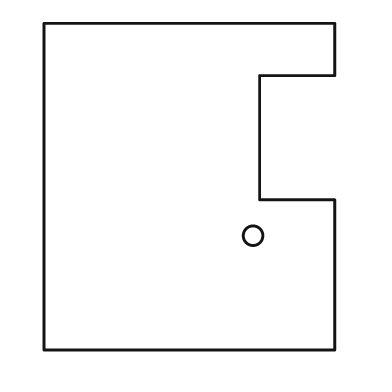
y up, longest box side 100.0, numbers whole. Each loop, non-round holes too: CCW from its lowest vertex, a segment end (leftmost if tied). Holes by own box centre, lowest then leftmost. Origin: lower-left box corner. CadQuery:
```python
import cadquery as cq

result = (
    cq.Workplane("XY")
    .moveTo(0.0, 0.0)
    .lineTo(89.0, 0.0)
    .lineTo(89.0, 46.0)
    .lineTo(66.0, 46.0)
    .lineTo(66.0, 84.0)
    .lineTo(89.0, 84.0)
    .lineTo(89.0, 100.0)
    .lineTo(0.0, 100.0)
    .close()
    .moveTo(64.0, 35.0)
    .circle(3.0)
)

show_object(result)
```